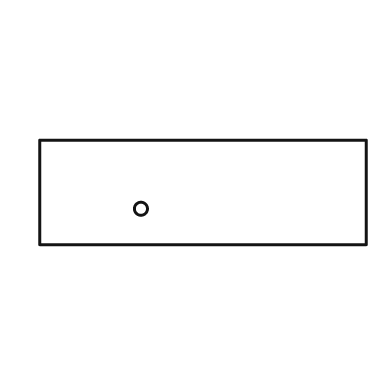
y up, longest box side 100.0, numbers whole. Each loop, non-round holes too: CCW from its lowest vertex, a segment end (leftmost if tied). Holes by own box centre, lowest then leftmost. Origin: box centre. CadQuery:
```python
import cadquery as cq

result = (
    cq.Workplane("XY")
    .moveTo(-50.0, -16.0)
    .lineTo(50.0, -16.0)
    .lineTo(50.0, 16.0)
    .lineTo(-50.0, 16.0)
    .close()
    .moveTo(-19.0, -5.0)
    .circle(2.0)
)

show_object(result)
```